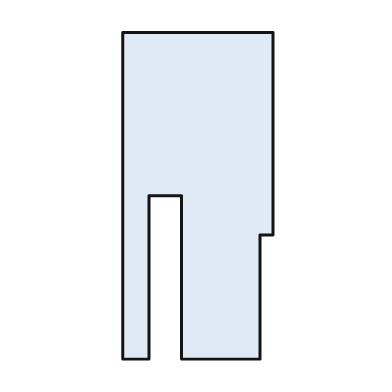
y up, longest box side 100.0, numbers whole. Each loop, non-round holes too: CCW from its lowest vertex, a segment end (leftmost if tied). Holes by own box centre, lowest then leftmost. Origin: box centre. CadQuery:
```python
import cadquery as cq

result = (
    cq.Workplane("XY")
    .moveTo(-23.0, -50.0)
    .lineTo(-15.0, -50.0)
    .lineTo(-15.0, 0.0)
    .lineTo(-5.0, 0.0)
    .lineTo(-5.0, -50.0)
    .lineTo(19.0, -50.0)
    .lineTo(19.0, -12.0)
    .lineTo(23.0, -12.0)
    .lineTo(23.0, 50.0)
    .lineTo(-23.0, 50.0)
    .close()
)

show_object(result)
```